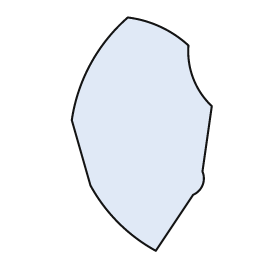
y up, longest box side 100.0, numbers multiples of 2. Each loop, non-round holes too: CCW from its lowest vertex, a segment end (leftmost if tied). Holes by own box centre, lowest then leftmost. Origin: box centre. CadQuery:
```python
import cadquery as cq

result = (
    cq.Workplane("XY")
    .moveTo(6.0, -50.0)
    .lineTo(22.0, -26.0)
    .threePointArc((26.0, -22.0), (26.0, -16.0))
    .lineTo(30.0, 12.0)
    .threePointArc((22.0, 24.0), (20.0, 38.0))
    .threePointArc((8.0, 46.0), (-6.0, 50.0))
    .threePointArc((-22.0, 30.0), (-30.0, 6.0))
    .lineTo(-22.0, -22.0)
    .threePointArc((-10.0, -38.0), (6.0, -50.0))
    .close()
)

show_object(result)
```